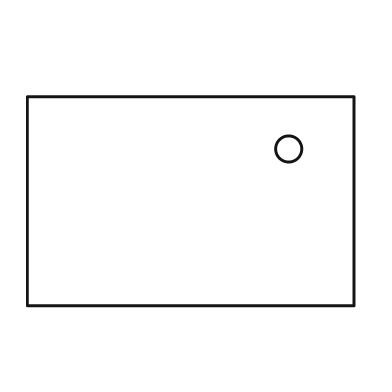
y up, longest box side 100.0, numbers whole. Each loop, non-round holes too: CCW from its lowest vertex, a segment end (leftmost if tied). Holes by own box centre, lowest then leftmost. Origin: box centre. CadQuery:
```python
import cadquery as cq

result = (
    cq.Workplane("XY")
    .moveTo(-50.0, -32.0)
    .lineTo(50.0, -32.0)
    .lineTo(50.0, 32.0)
    .lineTo(-50.0, 32.0)
    .close()
    .moveTo(30.0, 16.0)
    .circle(4.0)
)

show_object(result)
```